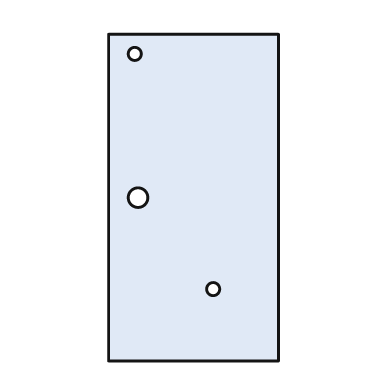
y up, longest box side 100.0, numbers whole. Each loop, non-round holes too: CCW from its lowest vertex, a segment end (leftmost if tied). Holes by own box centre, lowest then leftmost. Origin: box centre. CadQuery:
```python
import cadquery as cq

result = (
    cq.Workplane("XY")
    .moveTo(-26.0, -50.0)
    .lineTo(26.0, -50.0)
    .lineTo(26.0, 50.0)
    .lineTo(-26.0, 50.0)
    .close()
    .moveTo(6.0, -28.0)
    .circle(2.0)
    .moveTo(-17.0, 0.0)
    .circle(3.0)
    .moveTo(-18.0, 44.0)
    .circle(2.0)
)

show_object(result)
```